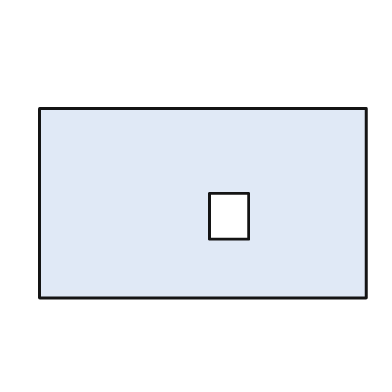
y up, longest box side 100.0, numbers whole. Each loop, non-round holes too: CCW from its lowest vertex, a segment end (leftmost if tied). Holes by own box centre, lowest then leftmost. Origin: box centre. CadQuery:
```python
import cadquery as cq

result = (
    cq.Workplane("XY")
    .moveTo(-50.0, -29.0)
    .lineTo(50.0, -29.0)
    .lineTo(50.0, 29.0)
    .lineTo(-50.0, 29.0)
    .close()
    .moveTo(2.0, -11.0)
    .lineTo(14.0, -11.0)
    .lineTo(14.0, 3.0)
    .lineTo(2.0, 3.0)
    .close()
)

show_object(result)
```